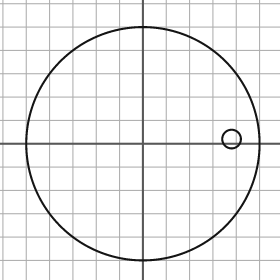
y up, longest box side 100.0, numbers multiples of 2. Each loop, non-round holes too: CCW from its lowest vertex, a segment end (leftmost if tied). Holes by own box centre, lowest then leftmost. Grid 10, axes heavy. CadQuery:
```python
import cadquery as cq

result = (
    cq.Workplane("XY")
    .moveTo(0.0, 0.0)
    .circle(50.0)
    .moveTo(38.0, 2.0)
    .circle(4.0)
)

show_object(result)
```